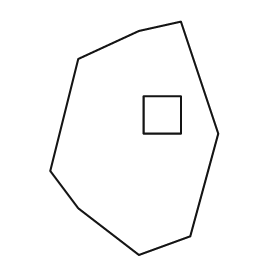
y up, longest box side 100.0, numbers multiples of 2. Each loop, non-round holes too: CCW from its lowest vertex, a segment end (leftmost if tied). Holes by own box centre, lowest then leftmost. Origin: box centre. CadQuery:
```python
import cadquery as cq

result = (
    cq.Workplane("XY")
    .moveTo(2.0, -50.0)
    .lineTo(24.0, -42.0)
    .lineTo(36.0, 2.0)
    .lineTo(20.0, 50.0)
    .lineTo(2.0, 46.0)
    .lineTo(-24.0, 34.0)
    .lineTo(-36.0, -14.0)
    .lineTo(-24.0, -30.0)
    .close()
    .moveTo(4.0, 2.0)
    .lineTo(20.0, 2.0)
    .lineTo(20.0, 18.0)
    .lineTo(4.0, 18.0)
    .close()
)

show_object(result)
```